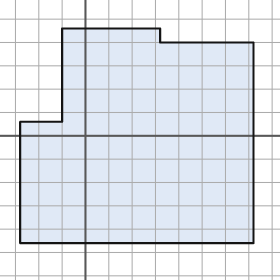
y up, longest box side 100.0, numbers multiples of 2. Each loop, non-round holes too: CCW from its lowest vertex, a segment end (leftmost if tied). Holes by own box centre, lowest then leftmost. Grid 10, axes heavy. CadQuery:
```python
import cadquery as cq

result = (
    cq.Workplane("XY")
    .moveTo(-28.0, -46.0)
    .lineTo(72.0, -46.0)
    .lineTo(72.0, 40.0)
    .lineTo(32.0, 40.0)
    .lineTo(32.0, 46.0)
    .lineTo(-10.0, 46.0)
    .lineTo(-10.0, 6.0)
    .lineTo(-28.0, 6.0)
    .close()
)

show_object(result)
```